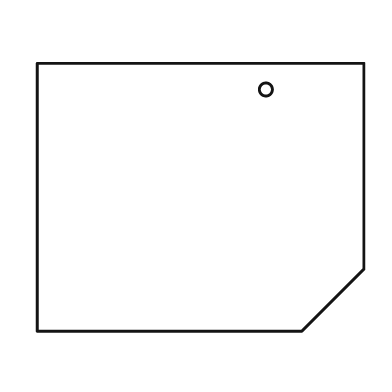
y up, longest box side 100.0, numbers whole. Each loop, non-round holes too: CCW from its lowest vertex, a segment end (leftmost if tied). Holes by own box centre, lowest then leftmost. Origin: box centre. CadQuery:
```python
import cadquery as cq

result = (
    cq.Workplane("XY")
    .moveTo(-50.0, -41.0)
    .lineTo(31.0, -41.0)
    .lineTo(50.0, -22.0)
    .lineTo(50.0, 41.0)
    .lineTo(-50.0, 41.0)
    .close()
    .moveTo(20.0, 33.0)
    .circle(2.0)
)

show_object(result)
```